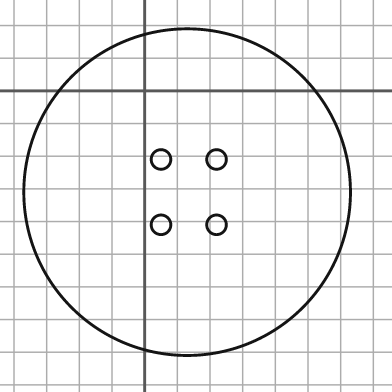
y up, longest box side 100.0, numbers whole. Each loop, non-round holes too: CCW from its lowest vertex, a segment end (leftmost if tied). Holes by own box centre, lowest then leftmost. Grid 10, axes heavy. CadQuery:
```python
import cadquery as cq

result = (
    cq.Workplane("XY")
    .moveTo(13.0, -31.0)
    .circle(50.0)
    .moveTo(5.0, -41.0)
    .circle(3.0)
    .moveTo(22.0, -41.0)
    .circle(3.0)
    .moveTo(5.0, -21.0)
    .circle(3.0)
    .moveTo(22.0, -21.0)
    .circle(3.0)
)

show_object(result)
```